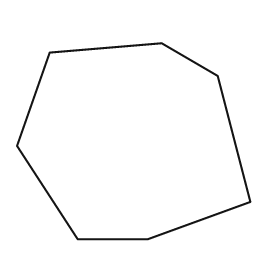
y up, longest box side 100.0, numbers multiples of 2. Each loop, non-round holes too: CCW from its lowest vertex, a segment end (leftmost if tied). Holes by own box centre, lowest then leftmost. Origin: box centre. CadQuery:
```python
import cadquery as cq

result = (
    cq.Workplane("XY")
    .moveTo(-24.0, -42.0)
    .lineTo(6.0, -42.0)
    .lineTo(50.0, -26.0)
    .lineTo(36.0, 28.0)
    .lineTo(12.0, 42.0)
    .lineTo(-36.0, 38.0)
    .lineTo(-50.0, -2.0)
    .close()
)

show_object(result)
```